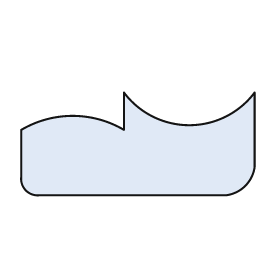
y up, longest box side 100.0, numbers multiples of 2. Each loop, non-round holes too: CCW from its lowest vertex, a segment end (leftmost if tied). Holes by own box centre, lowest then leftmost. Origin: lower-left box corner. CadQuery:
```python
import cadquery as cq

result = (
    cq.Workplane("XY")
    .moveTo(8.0, 0.0)
    .lineTo(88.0, 0.0)
    .threePointArc((96.0, 4.0), (100.0, 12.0))
    .lineTo(100.0, 44.0)
    .threePointArc((72.0, 30.0), (44.0, 44.0))
    .lineTo(44.0, 28.0)
    .threePointArc((22.0, 34.0), (0.0, 28.0))
    .lineTo(0.0, 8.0)
    .threePointArc((2.0, 2.0), (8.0, 0.0))
    .close()
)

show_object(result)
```